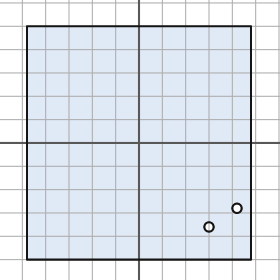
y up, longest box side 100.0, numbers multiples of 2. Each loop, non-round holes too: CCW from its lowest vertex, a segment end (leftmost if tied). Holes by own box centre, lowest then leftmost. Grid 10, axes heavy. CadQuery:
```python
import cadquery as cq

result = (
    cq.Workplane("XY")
    .moveTo(-48.0, -50.0)
    .lineTo(48.0, -50.0)
    .lineTo(48.0, 50.0)
    .lineTo(-48.0, 50.0)
    .close()
    .moveTo(30.0, -36.0)
    .circle(2.0)
    .moveTo(42.0, -28.0)
    .circle(2.0)
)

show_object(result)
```